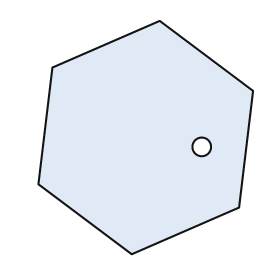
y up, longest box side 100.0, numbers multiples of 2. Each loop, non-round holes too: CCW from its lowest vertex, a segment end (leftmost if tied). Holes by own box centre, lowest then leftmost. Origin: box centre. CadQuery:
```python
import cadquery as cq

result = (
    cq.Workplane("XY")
    .moveTo(-6.0, -50.0)
    .lineTo(40.0, -30.0)
    .lineTo(46.0, 20.0)
    .lineTo(6.0, 50.0)
    .lineTo(-40.0, 30.0)
    .lineTo(-46.0, -20.0)
    .close()
    .moveTo(24.0, -4.0)
    .circle(4.0)
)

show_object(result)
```